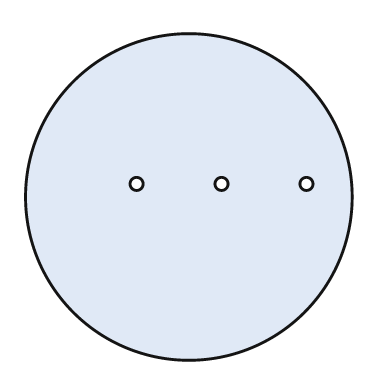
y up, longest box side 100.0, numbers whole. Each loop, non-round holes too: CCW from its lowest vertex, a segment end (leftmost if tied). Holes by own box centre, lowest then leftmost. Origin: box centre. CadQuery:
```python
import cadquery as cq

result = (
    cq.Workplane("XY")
    .moveTo(0.0, 0.0)
    .circle(50.0)
    .moveTo(-16.0, 4.0)
    .circle(2.0)
    .moveTo(10.0, 4.0)
    .circle(2.0)
    .moveTo(36.0, 4.0)
    .circle(2.0)
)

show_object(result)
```